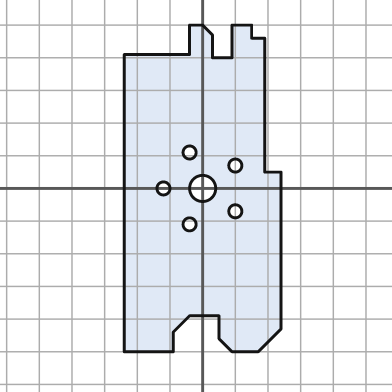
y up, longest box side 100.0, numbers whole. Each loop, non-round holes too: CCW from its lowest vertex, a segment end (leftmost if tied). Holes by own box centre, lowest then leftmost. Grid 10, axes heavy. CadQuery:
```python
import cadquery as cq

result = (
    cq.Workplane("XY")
    .moveTo(-24.0, -50.0)
    .lineTo(-9.0, -50.0)
    .lineTo(-9.0, -44.0)
    .lineTo(-4.0, -39.0)
    .lineTo(5.0, -39.0)
    .lineTo(5.0, -46.0)
    .lineTo(9.0, -50.0)
    .lineTo(17.0, -50.0)
    .lineTo(24.0, -43.0)
    .lineTo(24.0, 5.0)
    .lineTo(19.0, 5.0)
    .lineTo(19.0, 46.0)
    .lineTo(15.0, 46.0)
    .lineTo(15.0, 50.0)
    .lineTo(9.0, 50.0)
    .lineTo(9.0, 40.0)
    .lineTo(3.0, 40.0)
    .lineTo(3.0, 47.0)
    .lineTo(0.0, 50.0)
    .lineTo(-4.0, 50.0)
    .lineTo(-4.0, 41.0)
    .lineTo(-24.0, 41.0)
    .close()
    .moveTo(-4.0, -11.0)
    .circle(2.0)
    .moveTo(10.0, -7.0)
    .circle(2.0)
    .moveTo(-12.0, 0.0)
    .circle(2.0)
    .moveTo(0.0, 0.0)
    .circle(4.0)
    .moveTo(10.0, 7.0)
    .circle(2.0)
    .moveTo(-4.0, 11.0)
    .circle(2.0)
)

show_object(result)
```